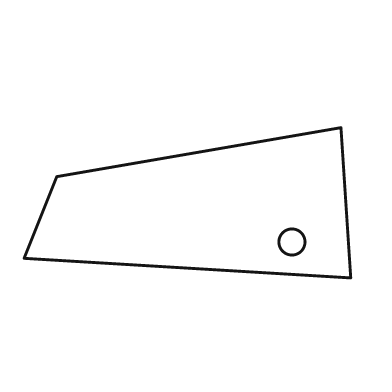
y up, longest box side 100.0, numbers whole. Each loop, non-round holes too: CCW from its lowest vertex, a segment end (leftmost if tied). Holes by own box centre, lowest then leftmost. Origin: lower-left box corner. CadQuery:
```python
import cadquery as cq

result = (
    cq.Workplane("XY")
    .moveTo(100.0, 0.0)
    .lineTo(97.0, 46.0)
    .lineTo(10.0, 31.0)
    .lineTo(0.0, 6.0)
    .close()
    .moveTo(82.0, 11.0)
    .circle(4.0)
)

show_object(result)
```